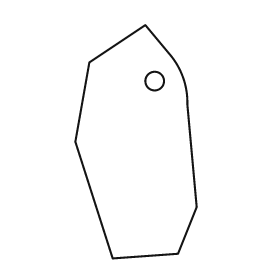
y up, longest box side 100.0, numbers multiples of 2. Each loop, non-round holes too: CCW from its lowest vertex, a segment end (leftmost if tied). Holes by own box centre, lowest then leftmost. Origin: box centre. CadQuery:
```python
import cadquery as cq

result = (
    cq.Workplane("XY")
    .moveTo(-10.0, -50.0)
    .lineTo(18.0, -48.0)
    .lineTo(26.0, -28.0)
    .lineTo(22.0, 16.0)
    .threePointArc((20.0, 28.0), (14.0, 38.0))
    .lineTo(4.0, 50.0)
    .lineTo(-20.0, 34.0)
    .lineTo(-26.0, 0.0)
    .close()
    .moveTo(8.0, 26.0)
    .circle(4.0)
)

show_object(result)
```